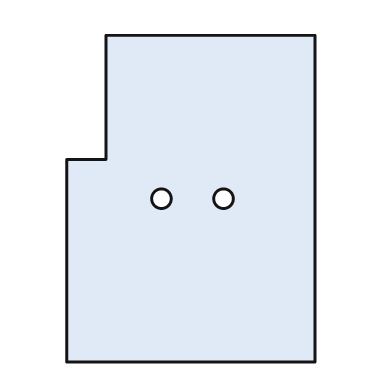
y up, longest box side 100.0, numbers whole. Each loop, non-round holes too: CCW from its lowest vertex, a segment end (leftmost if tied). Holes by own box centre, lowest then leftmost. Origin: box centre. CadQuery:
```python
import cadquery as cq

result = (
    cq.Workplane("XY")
    .moveTo(-38.0, -50.0)
    .lineTo(38.0, -50.0)
    .lineTo(38.0, 50.0)
    .lineTo(-26.0, 50.0)
    .lineTo(-26.0, 12.0)
    .lineTo(-38.0, 12.0)
    .close()
    .moveTo(-9.0, 0.0)
    .circle(3.0)
    .moveTo(10.0, 0.0)
    .circle(3.0)
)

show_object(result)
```